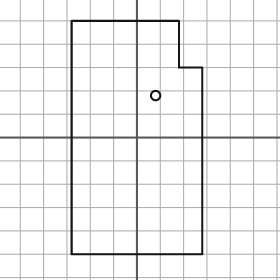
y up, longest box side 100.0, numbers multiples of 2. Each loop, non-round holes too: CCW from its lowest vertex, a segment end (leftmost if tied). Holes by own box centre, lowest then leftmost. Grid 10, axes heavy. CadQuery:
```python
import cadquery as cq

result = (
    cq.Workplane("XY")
    .moveTo(-28.0, -50.0)
    .lineTo(28.0, -50.0)
    .lineTo(28.0, 30.0)
    .lineTo(18.0, 30.0)
    .lineTo(18.0, 50.0)
    .lineTo(-28.0, 50.0)
    .close()
    .moveTo(8.0, 18.0)
    .circle(2.0)
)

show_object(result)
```